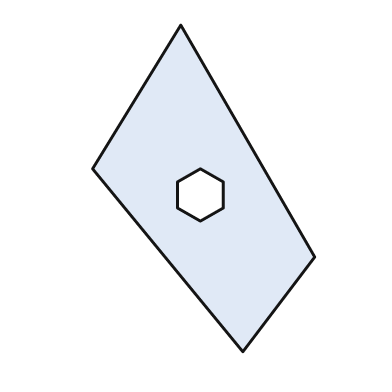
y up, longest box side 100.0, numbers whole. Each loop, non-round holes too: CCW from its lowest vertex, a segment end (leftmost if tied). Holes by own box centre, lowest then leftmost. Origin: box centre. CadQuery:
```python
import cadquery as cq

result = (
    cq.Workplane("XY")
    .moveTo(12.0, -50.0)
    .lineTo(34.0, -21.0)
    .lineTo(-7.0, 50.0)
    .lineTo(-34.0, 6.0)
    .close()
    .moveTo(-1.0, -10.0)
    .lineTo(6.0, -6.0)
    .lineTo(6.0, 2.0)
    .lineTo(-1.0, 6.0)
    .lineTo(-8.0, 2.0)
    .lineTo(-8.0, -6.0)
    .close()
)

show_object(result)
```